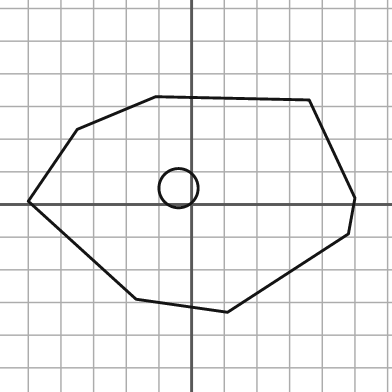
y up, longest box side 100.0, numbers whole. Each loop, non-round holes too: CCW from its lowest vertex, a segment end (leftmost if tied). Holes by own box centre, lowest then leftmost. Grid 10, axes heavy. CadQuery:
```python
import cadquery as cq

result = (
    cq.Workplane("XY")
    .moveTo(11.0, -33.0)
    .lineTo(48.0, -9.0)
    .lineTo(50.0, 2.0)
    .lineTo(36.0, 32.0)
    .lineTo(-11.0, 33.0)
    .lineTo(-35.0, 23.0)
    .lineTo(-50.0, 1.0)
    .lineTo(-17.0, -29.0)
    .close()
    .moveTo(-4.0, 5.0)
    .circle(6.0)
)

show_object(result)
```